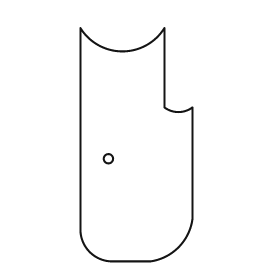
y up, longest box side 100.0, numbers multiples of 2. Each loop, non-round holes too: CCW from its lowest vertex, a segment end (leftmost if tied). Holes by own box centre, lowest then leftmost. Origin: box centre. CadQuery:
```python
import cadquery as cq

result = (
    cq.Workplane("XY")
    .moveTo(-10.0, -50.0)
    .lineTo(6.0, -50.0)
    .threePointArc((18.0, -44.0), (24.0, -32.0))
    .lineTo(24.0, 16.0)
    .threePointArc((18.0, 14.0), (12.0, 16.0))
    .lineTo(12.0, 50.0)
    .threePointArc((-6.0, 40.0), (-24.0, 50.0))
    .lineTo(-24.0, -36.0)
    .threePointArc((-20.0, -46.0), (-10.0, -50.0))
    .close()
    .moveTo(-12.0, -6.0)
    .circle(2.0)
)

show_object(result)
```